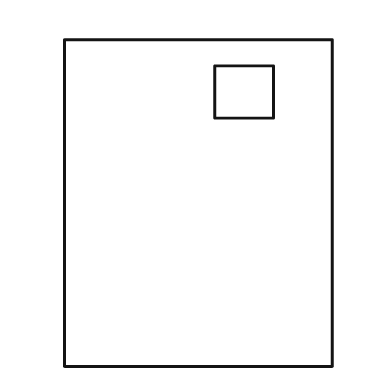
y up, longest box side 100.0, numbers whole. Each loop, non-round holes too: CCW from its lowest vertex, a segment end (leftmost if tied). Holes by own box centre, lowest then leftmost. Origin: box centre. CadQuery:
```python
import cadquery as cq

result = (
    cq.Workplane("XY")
    .moveTo(-41.0, -50.0)
    .lineTo(41.0, -50.0)
    .lineTo(41.0, 50.0)
    .lineTo(-41.0, 50.0)
    .close()
    .moveTo(5.0, 26.0)
    .lineTo(23.0, 26.0)
    .lineTo(23.0, 42.0)
    .lineTo(5.0, 42.0)
    .close()
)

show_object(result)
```